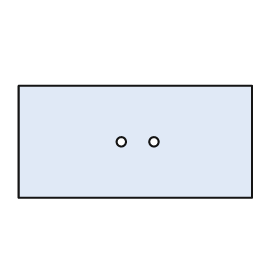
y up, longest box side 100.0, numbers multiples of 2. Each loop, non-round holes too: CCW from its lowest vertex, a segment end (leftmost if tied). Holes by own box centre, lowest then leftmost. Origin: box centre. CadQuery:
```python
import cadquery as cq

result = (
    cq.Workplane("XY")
    .moveTo(-50.0, -24.0)
    .lineTo(50.0, -24.0)
    .lineTo(50.0, 24.0)
    .lineTo(-50.0, 24.0)
    .close()
    .moveTo(-6.0, 0.0)
    .circle(2.0)
    .moveTo(8.0, 0.0)
    .circle(2.0)
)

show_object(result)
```